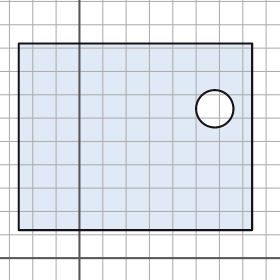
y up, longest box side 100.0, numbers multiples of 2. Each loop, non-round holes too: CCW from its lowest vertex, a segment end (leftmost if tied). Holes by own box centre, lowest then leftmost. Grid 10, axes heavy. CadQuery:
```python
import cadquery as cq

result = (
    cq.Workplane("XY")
    .moveTo(-26.0, 12.0)
    .lineTo(74.0, 12.0)
    .lineTo(74.0, 92.0)
    .lineTo(-26.0, 92.0)
    .close()
    .moveTo(58.0, 64.0)
    .circle(8.0)
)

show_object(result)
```